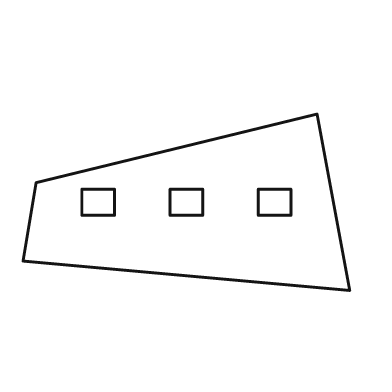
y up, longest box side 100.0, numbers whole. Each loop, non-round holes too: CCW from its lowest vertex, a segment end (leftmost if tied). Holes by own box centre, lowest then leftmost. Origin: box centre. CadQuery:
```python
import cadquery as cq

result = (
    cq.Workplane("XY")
    .moveTo(50.0, -27.0)
    .lineTo(40.0, 27.0)
    .lineTo(-46.0, 6.0)
    .lineTo(-50.0, -18.0)
    .close()
    .moveTo(-32.0, -4.0)
    .lineTo(-22.0, -4.0)
    .lineTo(-22.0, 4.0)
    .lineTo(-32.0, 4.0)
    .close()
    .moveTo(-5.0, -4.0)
    .lineTo(5.0, -4.0)
    .lineTo(5.0, 4.0)
    .lineTo(-5.0, 4.0)
    .close()
    .moveTo(22.0, -4.0)
    .lineTo(32.0, -4.0)
    .lineTo(32.0, 4.0)
    .lineTo(22.0, 4.0)
    .close()
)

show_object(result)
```